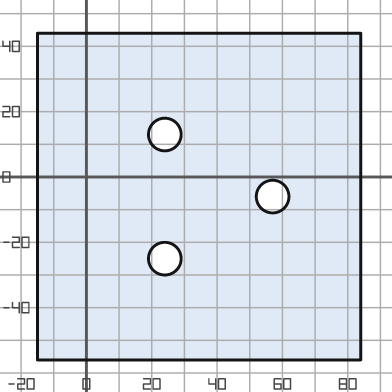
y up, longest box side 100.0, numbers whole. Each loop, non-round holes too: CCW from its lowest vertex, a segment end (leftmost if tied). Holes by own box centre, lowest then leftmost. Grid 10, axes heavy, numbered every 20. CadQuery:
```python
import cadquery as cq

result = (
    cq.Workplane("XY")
    .moveTo(-15.0, -56.0)
    .lineTo(84.0, -56.0)
    .lineTo(84.0, 44.0)
    .lineTo(-15.0, 44.0)
    .close()
    .moveTo(24.0, -25.0)
    .circle(5.0)
    .moveTo(57.0, -6.0)
    .circle(5.0)
    .moveTo(24.0, 13.0)
    .circle(5.0)
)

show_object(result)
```